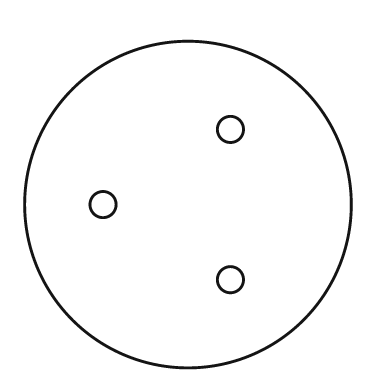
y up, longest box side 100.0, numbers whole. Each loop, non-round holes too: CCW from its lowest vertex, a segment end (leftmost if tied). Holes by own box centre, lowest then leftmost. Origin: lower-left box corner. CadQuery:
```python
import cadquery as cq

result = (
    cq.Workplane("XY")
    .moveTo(50.0, 50.0)
    .circle(50.0)
    .moveTo(63.0, 27.0)
    .circle(4.0)
    .moveTo(24.0, 50.0)
    .circle(4.0)
    .moveTo(63.0, 73.0)
    .circle(4.0)
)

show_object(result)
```